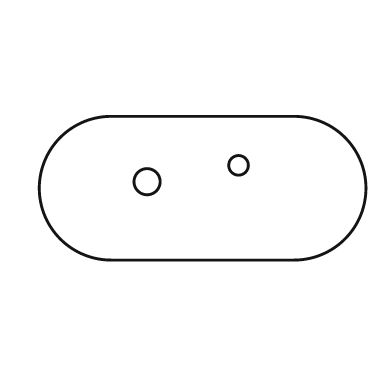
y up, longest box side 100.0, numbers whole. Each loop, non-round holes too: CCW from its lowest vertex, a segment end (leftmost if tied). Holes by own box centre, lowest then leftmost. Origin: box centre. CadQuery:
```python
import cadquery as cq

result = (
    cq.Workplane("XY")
    .moveTo(-28.0, -22.0)
    .lineTo(28.0, -22.0)
    .threePointArc((50.0, 0.0), (28.0, 22.0))
    .lineTo(-28.0, 22.0)
    .threePointArc((-50.0, 0.0), (-28.0, -22.0))
    .close()
    .moveTo(-17.0, 2.0)
    .circle(4.0)
    .moveTo(11.0, 7.0)
    .circle(3.0)
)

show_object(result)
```